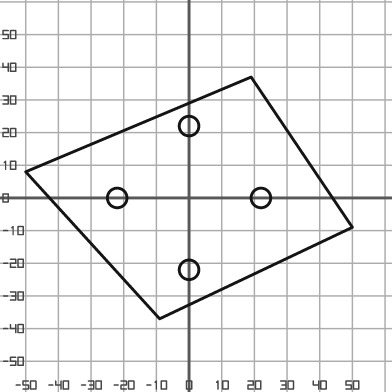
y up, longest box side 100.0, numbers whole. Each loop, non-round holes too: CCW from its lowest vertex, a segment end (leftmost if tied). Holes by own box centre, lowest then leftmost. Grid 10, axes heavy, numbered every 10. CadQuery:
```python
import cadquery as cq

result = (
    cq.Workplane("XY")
    .moveTo(-9.0, -37.0)
    .lineTo(50.0, -9.0)
    .lineTo(19.0, 37.0)
    .lineTo(-50.0, 8.0)
    .close()
    .moveTo(0.0, -22.0)
    .circle(3.0)
    .moveTo(-22.0, 0.0)
    .circle(3.0)
    .moveTo(22.0, 0.0)
    .circle(3.0)
    .moveTo(0.0, 22.0)
    .circle(3.0)
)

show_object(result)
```